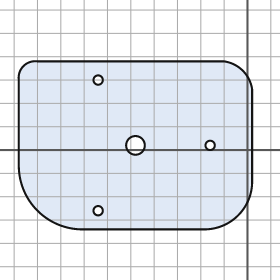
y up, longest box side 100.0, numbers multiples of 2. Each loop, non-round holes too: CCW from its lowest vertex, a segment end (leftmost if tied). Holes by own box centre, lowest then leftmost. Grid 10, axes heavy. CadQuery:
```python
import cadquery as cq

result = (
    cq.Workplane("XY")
    .moveTo(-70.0, -34.0)
    .lineTo(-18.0, -34.0)
    .threePointArc((-4.0, -28.0), (2.0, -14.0))
    .lineTo(2.0, 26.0)
    .threePointArc((-2.0, 34.0), (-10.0, 38.0))
    .lineTo(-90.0, 38.0)
    .threePointArc((-96.0, 36.0), (-98.0, 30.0))
    .lineTo(-98.0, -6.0)
    .threePointArc((-90.0, -26.0), (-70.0, -34.0))
    .close()
    .moveTo(-64.0, -26.0)
    .circle(2.0)
    .moveTo(-48.0, 2.0)
    .circle(4.0)
    .moveTo(-16.0, 2.0)
    .circle(2.0)
    .moveTo(-64.0, 30.0)
    .circle(2.0)
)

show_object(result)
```